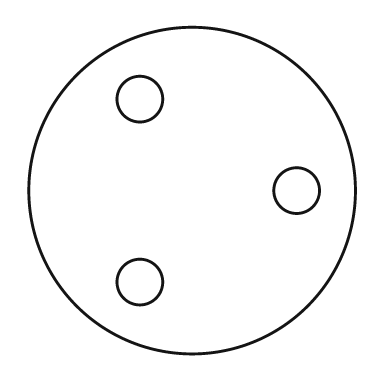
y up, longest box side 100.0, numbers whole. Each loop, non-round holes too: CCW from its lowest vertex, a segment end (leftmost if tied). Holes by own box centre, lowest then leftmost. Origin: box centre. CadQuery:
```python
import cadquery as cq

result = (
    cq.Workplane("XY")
    .moveTo(0.0, 0.0)
    .circle(50.0)
    .moveTo(-16.0, -28.0)
    .circle(7.0)
    .moveTo(32.0, 0.0)
    .circle(7.0)
    .moveTo(-16.0, 28.0)
    .circle(7.0)
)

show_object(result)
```